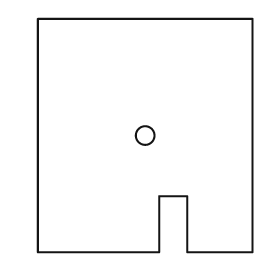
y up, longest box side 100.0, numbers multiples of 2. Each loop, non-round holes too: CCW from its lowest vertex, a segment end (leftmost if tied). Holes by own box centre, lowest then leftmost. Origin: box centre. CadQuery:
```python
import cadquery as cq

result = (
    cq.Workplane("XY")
    .moveTo(-46.0, -50.0)
    .lineTo(6.0, -50.0)
    .lineTo(6.0, -26.0)
    .lineTo(18.0, -26.0)
    .lineTo(18.0, -50.0)
    .lineTo(46.0, -50.0)
    .lineTo(46.0, 50.0)
    .lineTo(-46.0, 50.0)
    .close()
    .moveTo(0.0, 0.0)
    .circle(4.0)
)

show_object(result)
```